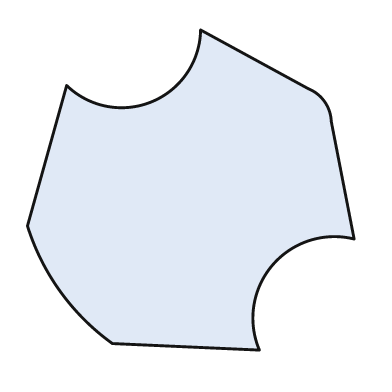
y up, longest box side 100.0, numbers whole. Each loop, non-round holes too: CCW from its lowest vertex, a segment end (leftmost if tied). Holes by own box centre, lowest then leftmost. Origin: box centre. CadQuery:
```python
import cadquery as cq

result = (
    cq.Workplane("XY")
    .moveTo(21.0, -49.0)
    .threePointArc((25.0, -23.0), (50.0, -15.0))
    .lineTo(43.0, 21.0)
    .threePointArc((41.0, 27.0), (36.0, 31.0))
    .lineTo(3.0, 49.0)
    .threePointArc((-12.0, 27.0), (-38.0, 32.0))
    .lineTo(-50.0, -11.0)
    .threePointArc((-40.0, -31.0), (-24.0, -47.0))
    .close()
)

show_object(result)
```